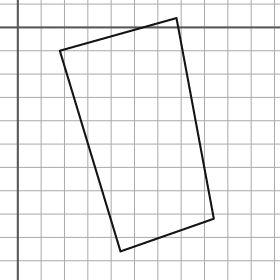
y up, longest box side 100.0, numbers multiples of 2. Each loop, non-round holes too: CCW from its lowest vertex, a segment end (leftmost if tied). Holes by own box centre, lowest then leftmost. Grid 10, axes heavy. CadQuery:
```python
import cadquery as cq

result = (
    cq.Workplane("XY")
    .moveTo(44.0, -96.0)
    .lineTo(84.0, -82.0)
    .lineTo(68.0, 4.0)
    .lineTo(18.0, -10.0)
    .close()
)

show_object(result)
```